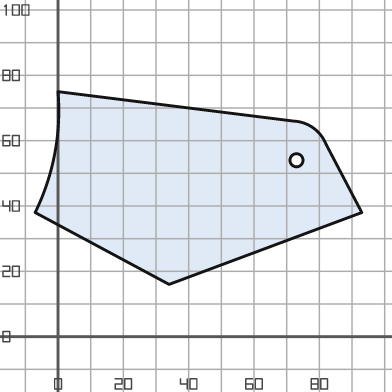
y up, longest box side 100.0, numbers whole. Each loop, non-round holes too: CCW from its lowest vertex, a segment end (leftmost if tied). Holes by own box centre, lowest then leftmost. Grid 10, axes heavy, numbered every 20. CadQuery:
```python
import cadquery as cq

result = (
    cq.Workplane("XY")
    .moveTo(34.0, 16.0)
    .lineTo(93.0, 38.0)
    .lineTo(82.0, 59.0)
    .threePointArc((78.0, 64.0), (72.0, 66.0))
    .lineTo(0.0, 75.0)
    .threePointArc((-1.0, 56.0), (-7.0, 38.0))
    .close()
    .moveTo(73.0, 54.0)
    .circle(2.0)
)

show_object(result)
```